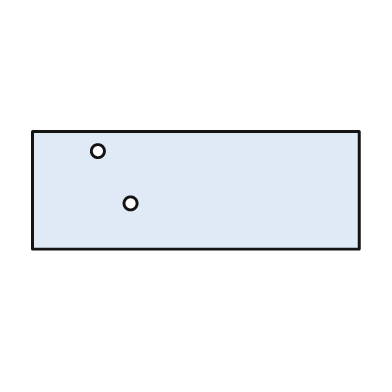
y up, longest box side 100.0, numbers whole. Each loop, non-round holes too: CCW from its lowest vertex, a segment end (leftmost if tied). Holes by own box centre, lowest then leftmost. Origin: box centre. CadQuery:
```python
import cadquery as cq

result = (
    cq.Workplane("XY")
    .moveTo(-50.0, -18.0)
    .lineTo(50.0, -18.0)
    .lineTo(50.0, 18.0)
    .lineTo(-50.0, 18.0)
    .close()
    .moveTo(-20.0, -4.0)
    .circle(2.0)
    .moveTo(-30.0, 12.0)
    .circle(2.0)
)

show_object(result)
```